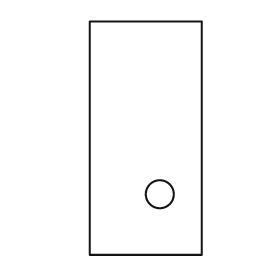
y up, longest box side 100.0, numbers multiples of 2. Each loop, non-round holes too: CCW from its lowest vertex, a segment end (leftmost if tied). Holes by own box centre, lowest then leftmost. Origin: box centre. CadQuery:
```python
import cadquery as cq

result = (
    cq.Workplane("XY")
    .moveTo(-24.0, -50.0)
    .lineTo(24.0, -50.0)
    .lineTo(24.0, 50.0)
    .lineTo(-24.0, 50.0)
    .close()
    .moveTo(6.0, -24.0)
    .circle(6.0)
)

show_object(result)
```